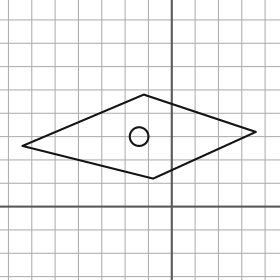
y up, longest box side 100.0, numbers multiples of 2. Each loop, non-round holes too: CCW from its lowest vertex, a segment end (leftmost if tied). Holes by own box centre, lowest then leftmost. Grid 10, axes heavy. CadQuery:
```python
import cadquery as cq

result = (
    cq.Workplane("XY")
    .moveTo(-8.0, 12.0)
    .lineTo(36.0, 32.0)
    .lineTo(-12.0, 48.0)
    .lineTo(-64.0, 26.0)
    .close()
    .moveTo(-14.0, 30.0)
    .circle(4.0)
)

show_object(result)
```